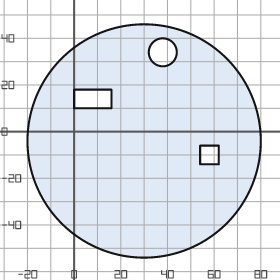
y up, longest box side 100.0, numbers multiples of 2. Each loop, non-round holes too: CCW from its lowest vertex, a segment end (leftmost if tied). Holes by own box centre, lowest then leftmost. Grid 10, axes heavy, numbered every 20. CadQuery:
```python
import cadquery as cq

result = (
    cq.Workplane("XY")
    .moveTo(30.0, -4.0)
    .circle(50.0)
    .moveTo(54.0, -14.0)
    .lineTo(62.0, -14.0)
    .lineTo(62.0, -6.0)
    .lineTo(54.0, -6.0)
    .close()
    .moveTo(0.0, 10.0)
    .lineTo(16.0, 10.0)
    .lineTo(16.0, 18.0)
    .lineTo(0.0, 18.0)
    .close()
    .moveTo(38.0, 34.0)
    .circle(6.0)
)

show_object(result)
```